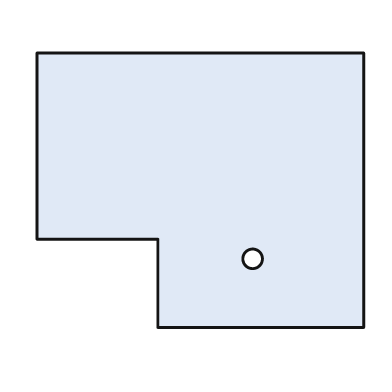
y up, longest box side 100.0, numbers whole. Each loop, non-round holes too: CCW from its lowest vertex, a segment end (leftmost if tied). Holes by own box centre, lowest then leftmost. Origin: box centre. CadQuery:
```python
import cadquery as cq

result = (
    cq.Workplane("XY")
    .moveTo(-13.0, -42.0)
    .lineTo(50.0, -42.0)
    .lineTo(50.0, 42.0)
    .lineTo(-50.0, 42.0)
    .lineTo(-50.0, -15.0)
    .lineTo(-13.0, -15.0)
    .close()
    .moveTo(16.0, -21.0)
    .circle(3.0)
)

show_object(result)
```